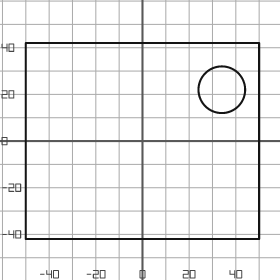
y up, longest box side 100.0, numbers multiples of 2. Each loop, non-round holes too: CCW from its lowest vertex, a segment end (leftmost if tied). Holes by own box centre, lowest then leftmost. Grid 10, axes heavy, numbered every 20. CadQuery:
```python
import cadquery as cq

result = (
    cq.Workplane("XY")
    .moveTo(-50.0, -42.0)
    .lineTo(50.0, -42.0)
    .lineTo(50.0, 42.0)
    .lineTo(-50.0, 42.0)
    .close()
    .moveTo(34.0, 22.0)
    .circle(10.0)
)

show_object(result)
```